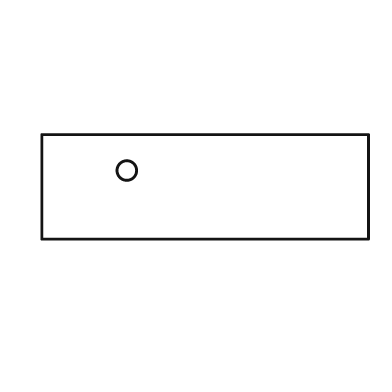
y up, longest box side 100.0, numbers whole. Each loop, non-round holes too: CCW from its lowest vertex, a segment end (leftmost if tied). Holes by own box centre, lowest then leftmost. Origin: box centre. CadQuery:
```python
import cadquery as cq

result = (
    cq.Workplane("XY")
    .moveTo(-50.0, -16.0)
    .lineTo(50.0, -16.0)
    .lineTo(50.0, 16.0)
    .lineTo(-50.0, 16.0)
    .close()
    .moveTo(-24.0, 5.0)
    .circle(3.0)
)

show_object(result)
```